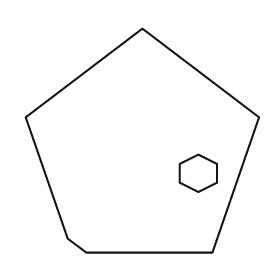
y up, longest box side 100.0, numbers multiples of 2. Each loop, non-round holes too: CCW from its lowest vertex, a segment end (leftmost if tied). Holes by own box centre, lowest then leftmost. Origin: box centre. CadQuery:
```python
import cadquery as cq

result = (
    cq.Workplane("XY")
    .moveTo(-24.0, -48.0)
    .lineTo(30.0, -48.0)
    .lineTo(50.0, 10.0)
    .lineTo(0.0, 48.0)
    .lineTo(-50.0, 10.0)
    .lineTo(-32.0, -42.0)
    .close()
    .moveTo(24.0, -22.0)
    .lineTo(32.0, -18.0)
    .lineTo(32.0, -10.0)
    .lineTo(24.0, -6.0)
    .lineTo(16.0, -10.0)
    .lineTo(16.0, -18.0)
    .close()
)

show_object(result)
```